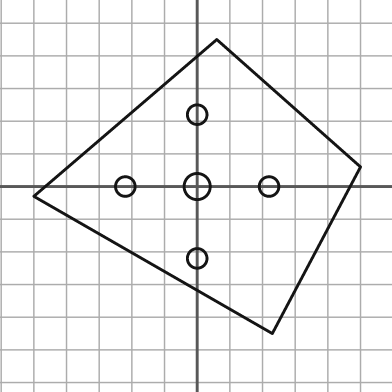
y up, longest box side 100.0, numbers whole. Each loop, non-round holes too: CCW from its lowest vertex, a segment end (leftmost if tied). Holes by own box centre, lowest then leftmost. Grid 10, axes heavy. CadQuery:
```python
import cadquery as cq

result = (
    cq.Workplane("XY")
    .moveTo(23.0, -45.0)
    .lineTo(50.0, 6.0)
    .lineTo(6.0, 45.0)
    .lineTo(-50.0, -3.0)
    .close()
    .moveTo(0.0, -22.0)
    .circle(3.0)
    .moveTo(-22.0, 0.0)
    .circle(3.0)
    .moveTo(0.0, 0.0)
    .circle(4.0)
    .moveTo(22.0, 0.0)
    .circle(3.0)
    .moveTo(0.0, 22.0)
    .circle(3.0)
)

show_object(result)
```